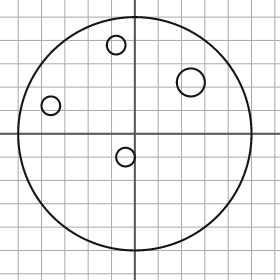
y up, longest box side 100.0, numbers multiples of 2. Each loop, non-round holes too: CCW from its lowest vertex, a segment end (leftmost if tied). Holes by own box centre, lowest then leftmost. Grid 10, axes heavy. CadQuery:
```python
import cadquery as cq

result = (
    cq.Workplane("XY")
    .moveTo(0.0, 0.0)
    .circle(50.0)
    .moveTo(-4.0, -10.0)
    .circle(4.0)
    .moveTo(-36.0, 12.0)
    .circle(4.0)
    .moveTo(24.0, 22.0)
    .circle(6.0)
    .moveTo(-8.0, 38.0)
    .circle(4.0)
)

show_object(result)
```